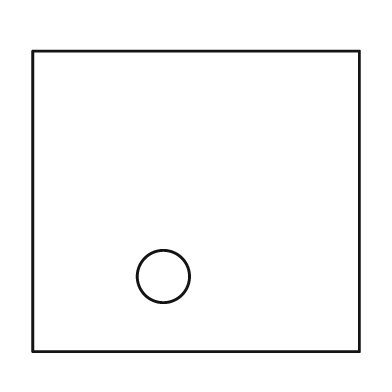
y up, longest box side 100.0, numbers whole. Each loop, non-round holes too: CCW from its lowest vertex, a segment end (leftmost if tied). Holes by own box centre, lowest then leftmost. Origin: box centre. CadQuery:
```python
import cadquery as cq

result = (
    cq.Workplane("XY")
    .moveTo(-50.0, -46.0)
    .lineTo(50.0, -46.0)
    .lineTo(50.0, 46.0)
    .lineTo(-50.0, 46.0)
    .close()
    .moveTo(-10.0, -23.0)
    .circle(8.0)
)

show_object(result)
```